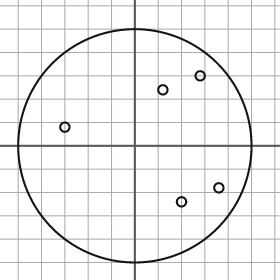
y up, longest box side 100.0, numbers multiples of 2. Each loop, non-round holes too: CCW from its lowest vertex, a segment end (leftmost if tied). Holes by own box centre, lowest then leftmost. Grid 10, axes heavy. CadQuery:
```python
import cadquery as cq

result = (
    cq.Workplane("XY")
    .moveTo(0.0, 0.0)
    .circle(50.0)
    .moveTo(20.0, -24.0)
    .circle(2.0)
    .moveTo(36.0, -18.0)
    .circle(2.0)
    .moveTo(-30.0, 8.0)
    .circle(2.0)
    .moveTo(12.0, 24.0)
    .circle(2.0)
    .moveTo(28.0, 30.0)
    .circle(2.0)
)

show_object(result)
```